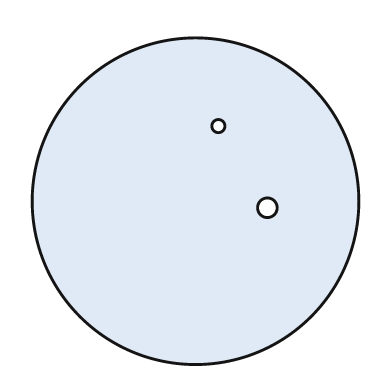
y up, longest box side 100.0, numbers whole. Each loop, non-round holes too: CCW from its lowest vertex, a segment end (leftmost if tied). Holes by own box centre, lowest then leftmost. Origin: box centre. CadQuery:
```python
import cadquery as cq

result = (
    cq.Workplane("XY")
    .moveTo(0.0, 0.0)
    .circle(50.0)
    .moveTo(22.0, -2.0)
    .circle(3.0)
    .moveTo(7.0, 23.0)
    .circle(2.0)
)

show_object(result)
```